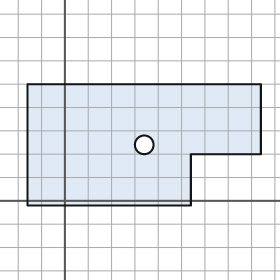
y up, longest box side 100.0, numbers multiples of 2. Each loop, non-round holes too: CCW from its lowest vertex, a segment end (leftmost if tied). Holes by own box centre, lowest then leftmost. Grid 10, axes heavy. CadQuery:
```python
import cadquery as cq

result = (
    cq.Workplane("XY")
    .moveTo(-16.0, -2.0)
    .lineTo(54.0, -2.0)
    .lineTo(54.0, 20.0)
    .lineTo(84.0, 20.0)
    .lineTo(84.0, 50.0)
    .lineTo(-16.0, 50.0)
    .close()
    .moveTo(34.0, 24.0)
    .circle(4.0)
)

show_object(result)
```